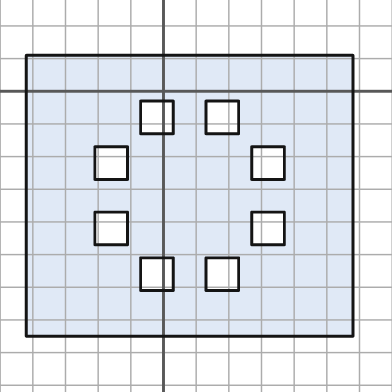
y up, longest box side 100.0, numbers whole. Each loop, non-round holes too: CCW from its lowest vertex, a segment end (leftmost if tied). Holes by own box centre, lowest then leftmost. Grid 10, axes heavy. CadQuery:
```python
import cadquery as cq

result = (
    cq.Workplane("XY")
    .moveTo(-42.0, -75.0)
    .lineTo(58.0, -75.0)
    .lineTo(58.0, 11.0)
    .lineTo(-42.0, 11.0)
    .close()
    .moveTo(-7.0, -61.0)
    .lineTo(3.0, -61.0)
    .lineTo(3.0, -51.0)
    .lineTo(-7.0, -51.0)
    .close()
    .moveTo(13.0, -61.0)
    .lineTo(23.0, -61.0)
    .lineTo(23.0, -51.0)
    .lineTo(13.0, -51.0)
    .close()
    .moveTo(-21.0, -47.0)
    .lineTo(-11.0, -47.0)
    .lineTo(-11.0, -37.0)
    .lineTo(-21.0, -37.0)
    .close()
    .moveTo(27.0, -47.0)
    .lineTo(37.0, -47.0)
    .lineTo(37.0, -37.0)
    .lineTo(27.0, -37.0)
    .close()
    .moveTo(-21.0, -27.0)
    .lineTo(-11.0, -27.0)
    .lineTo(-11.0, -17.0)
    .lineTo(-21.0, -17.0)
    .close()
    .moveTo(27.0, -27.0)
    .lineTo(37.0, -27.0)
    .lineTo(37.0, -17.0)
    .lineTo(27.0, -17.0)
    .close()
    .moveTo(-7.0, -13.0)
    .lineTo(3.0, -13.0)
    .lineTo(3.0, -3.0)
    .lineTo(-7.0, -3.0)
    .close()
    .moveTo(13.0, -13.0)
    .lineTo(23.0, -13.0)
    .lineTo(23.0, -3.0)
    .lineTo(13.0, -3.0)
    .close()
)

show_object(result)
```